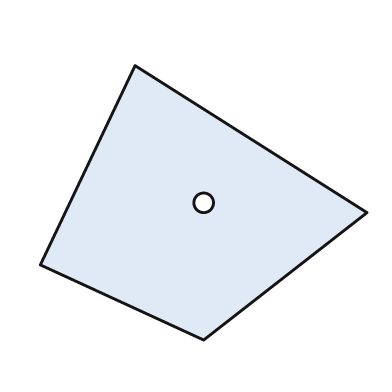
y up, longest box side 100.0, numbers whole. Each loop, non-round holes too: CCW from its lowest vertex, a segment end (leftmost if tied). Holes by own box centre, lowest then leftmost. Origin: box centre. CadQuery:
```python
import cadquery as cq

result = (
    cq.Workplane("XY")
    .moveTo(0.0, -42.0)
    .lineTo(50.0, -3.0)
    .lineTo(-21.0, 42.0)
    .lineTo(-50.0, -19.0)
    .close()
    .moveTo(0.0, 0.0)
    .circle(3.0)
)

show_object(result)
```